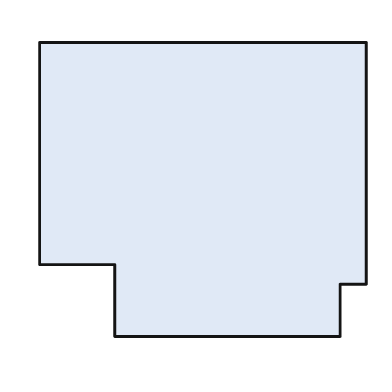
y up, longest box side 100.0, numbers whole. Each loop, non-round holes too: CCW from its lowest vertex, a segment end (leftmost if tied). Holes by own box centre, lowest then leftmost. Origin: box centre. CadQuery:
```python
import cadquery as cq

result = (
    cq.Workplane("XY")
    .moveTo(-27.0, -45.0)
    .lineTo(42.0, -45.0)
    .lineTo(42.0, -29.0)
    .lineTo(50.0, -29.0)
    .lineTo(50.0, 45.0)
    .lineTo(-50.0, 45.0)
    .lineTo(-50.0, -23.0)
    .lineTo(-27.0, -23.0)
    .close()
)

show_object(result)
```